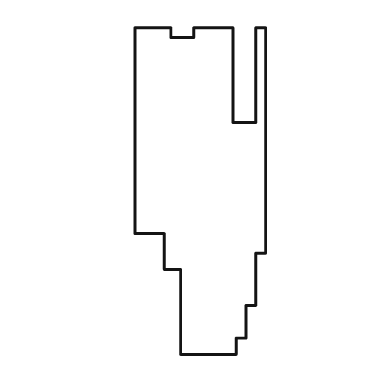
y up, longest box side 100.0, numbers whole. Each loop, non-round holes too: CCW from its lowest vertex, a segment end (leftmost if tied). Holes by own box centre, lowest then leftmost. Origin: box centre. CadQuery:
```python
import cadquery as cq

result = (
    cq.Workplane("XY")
    .moveTo(-6.0, -50.0)
    .lineTo(11.0, -50.0)
    .lineTo(11.0, -45.0)
    .lineTo(14.0, -45.0)
    .lineTo(14.0, -35.0)
    .lineTo(17.0, -35.0)
    .lineTo(17.0, -19.0)
    .lineTo(20.0, -19.0)
    .lineTo(20.0, 50.0)
    .lineTo(17.0, 50.0)
    .lineTo(17.0, 21.0)
    .lineTo(10.0, 21.0)
    .lineTo(10.0, 50.0)
    .lineTo(-2.0, 50.0)
    .lineTo(-2.0, 47.0)
    .lineTo(-9.0, 47.0)
    .lineTo(-9.0, 50.0)
    .lineTo(-20.0, 50.0)
    .lineTo(-20.0, -13.0)
    .lineTo(-11.0, -13.0)
    .lineTo(-11.0, -24.0)
    .lineTo(-6.0, -24.0)
    .close()
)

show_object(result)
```